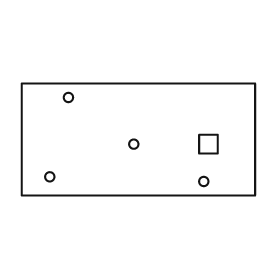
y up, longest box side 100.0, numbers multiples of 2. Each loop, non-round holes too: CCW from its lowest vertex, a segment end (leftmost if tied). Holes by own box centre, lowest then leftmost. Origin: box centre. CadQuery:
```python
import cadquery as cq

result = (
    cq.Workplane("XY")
    .moveTo(-50.0, -24.0)
    .lineTo(50.0, -24.0)
    .lineTo(50.0, 24.0)
    .lineTo(-50.0, 24.0)
    .close()
    .moveTo(28.0, -18.0)
    .circle(2.0)
    .moveTo(-38.0, -16.0)
    .circle(2.0)
    .moveTo(-2.0, -2.0)
    .circle(2.0)
    .moveTo(26.0, -6.0)
    .lineTo(34.0, -6.0)
    .lineTo(34.0, 2.0)
    .lineTo(26.0, 2.0)
    .close()
    .moveTo(-30.0, 18.0)
    .circle(2.0)
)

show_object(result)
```